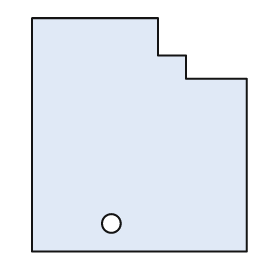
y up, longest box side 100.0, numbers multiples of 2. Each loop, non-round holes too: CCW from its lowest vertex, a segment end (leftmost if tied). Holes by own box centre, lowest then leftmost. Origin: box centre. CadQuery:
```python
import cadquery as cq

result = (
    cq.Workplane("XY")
    .moveTo(-46.0, -50.0)
    .lineTo(46.0, -50.0)
    .lineTo(46.0, 24.0)
    .lineTo(20.0, 24.0)
    .lineTo(20.0, 34.0)
    .lineTo(8.0, 34.0)
    .lineTo(8.0, 50.0)
    .lineTo(-46.0, 50.0)
    .close()
    .moveTo(-12.0, -38.0)
    .circle(4.0)
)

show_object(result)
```